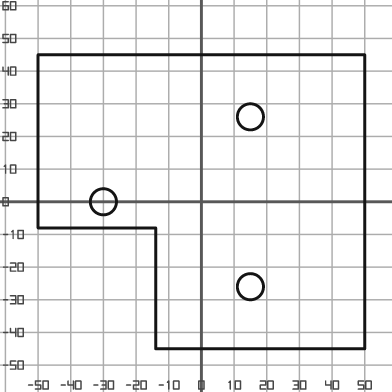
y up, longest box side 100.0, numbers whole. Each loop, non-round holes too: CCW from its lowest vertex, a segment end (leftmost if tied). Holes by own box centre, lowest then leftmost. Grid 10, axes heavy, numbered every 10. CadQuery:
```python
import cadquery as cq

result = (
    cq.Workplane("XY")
    .moveTo(-14.0, -45.0)
    .lineTo(50.0, -45.0)
    .lineTo(50.0, 45.0)
    .lineTo(-50.0, 45.0)
    .lineTo(-50.0, -8.0)
    .lineTo(-14.0, -8.0)
    .close()
    .moveTo(15.0, -26.0)
    .circle(4.0)
    .moveTo(-30.0, 0.0)
    .circle(4.0)
    .moveTo(15.0, 26.0)
    .circle(4.0)
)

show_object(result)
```